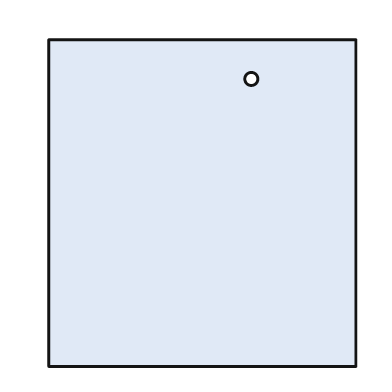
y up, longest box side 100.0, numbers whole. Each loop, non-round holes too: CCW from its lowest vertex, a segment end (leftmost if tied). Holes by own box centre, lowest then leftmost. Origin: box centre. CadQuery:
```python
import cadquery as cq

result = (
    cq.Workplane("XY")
    .moveTo(-47.0, -50.0)
    .lineTo(47.0, -50.0)
    .lineTo(47.0, 50.0)
    .lineTo(-47.0, 50.0)
    .close()
    .moveTo(15.0, 38.0)
    .circle(2.0)
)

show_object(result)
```